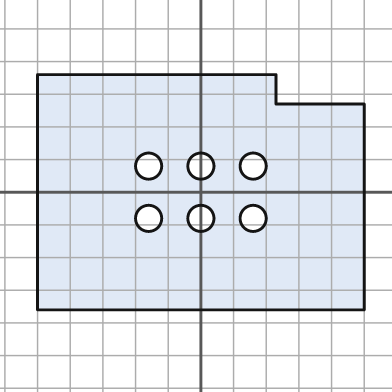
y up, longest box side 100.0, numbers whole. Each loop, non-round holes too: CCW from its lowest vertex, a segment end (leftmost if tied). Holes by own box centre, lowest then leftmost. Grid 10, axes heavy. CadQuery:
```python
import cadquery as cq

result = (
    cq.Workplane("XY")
    .moveTo(-50.0, -36.0)
    .lineTo(50.0, -36.0)
    .lineTo(50.0, 27.0)
    .lineTo(23.0, 27.0)
    .lineTo(23.0, 36.0)
    .lineTo(-50.0, 36.0)
    .close()
    .moveTo(-16.0, -8.0)
    .circle(4.0)
    .moveTo(0.0, -8.0)
    .circle(4.0)
    .moveTo(16.0, -8.0)
    .circle(4.0)
    .moveTo(-16.0, 8.0)
    .circle(4.0)
    .moveTo(0.0, 8.0)
    .circle(4.0)
    .moveTo(16.0, 8.0)
    .circle(4.0)
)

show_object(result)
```